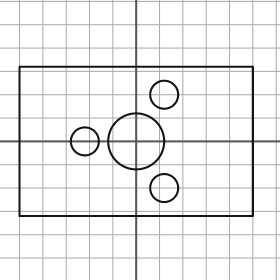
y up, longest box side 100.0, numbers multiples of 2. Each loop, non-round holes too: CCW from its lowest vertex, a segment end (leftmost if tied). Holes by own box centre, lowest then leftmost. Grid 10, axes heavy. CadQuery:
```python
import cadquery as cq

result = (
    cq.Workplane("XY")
    .moveTo(-50.0, -32.0)
    .lineTo(50.0, -32.0)
    .lineTo(50.0, 32.0)
    .lineTo(-50.0, 32.0)
    .close()
    .moveTo(12.0, -20.0)
    .circle(6.0)
    .moveTo(-22.0, 0.0)
    .circle(6.0)
    .moveTo(0.0, 0.0)
    .circle(12.0)
    .moveTo(12.0, 20.0)
    .circle(6.0)
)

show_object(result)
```